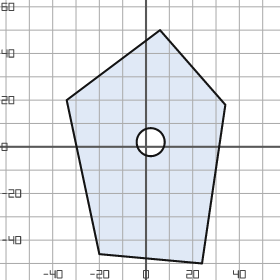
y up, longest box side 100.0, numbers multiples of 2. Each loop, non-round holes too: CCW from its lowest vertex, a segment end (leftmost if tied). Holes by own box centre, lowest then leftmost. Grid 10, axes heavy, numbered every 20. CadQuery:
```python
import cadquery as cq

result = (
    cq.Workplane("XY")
    .moveTo(24.0, -50.0)
    .lineTo(34.0, 18.0)
    .lineTo(6.0, 50.0)
    .lineTo(-34.0, 20.0)
    .lineTo(-20.0, -46.0)
    .close()
    .moveTo(2.0, 2.0)
    .circle(6.0)
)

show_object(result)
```